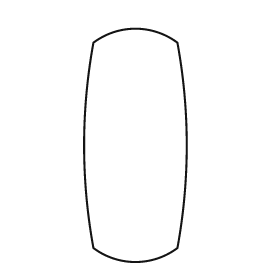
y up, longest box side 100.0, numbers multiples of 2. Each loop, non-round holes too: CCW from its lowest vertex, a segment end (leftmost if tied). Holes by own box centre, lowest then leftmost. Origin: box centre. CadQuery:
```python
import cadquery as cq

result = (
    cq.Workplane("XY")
    .moveTo(-18.0, -44.0)
    .threePointArc((0.0, -50.0), (18.0, -44.0))
    .threePointArc((22.0, 0.0), (18.0, 44.0))
    .threePointArc((0.0, 50.0), (-18.0, 44.0))
    .threePointArc((-22.0, 0.0), (-18.0, -44.0))
    .close()
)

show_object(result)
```